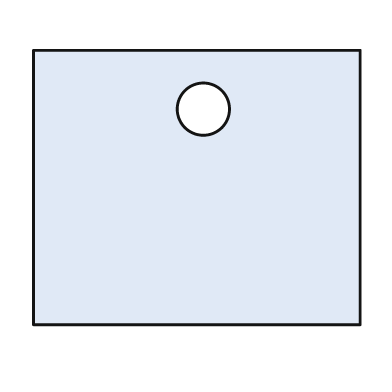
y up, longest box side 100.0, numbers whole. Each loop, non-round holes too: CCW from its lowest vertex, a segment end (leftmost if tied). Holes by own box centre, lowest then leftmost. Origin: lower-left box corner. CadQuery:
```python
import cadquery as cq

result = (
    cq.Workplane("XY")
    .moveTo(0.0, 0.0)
    .lineTo(100.0, 0.0)
    .lineTo(100.0, 84.0)
    .lineTo(0.0, 84.0)
    .close()
    .moveTo(52.0, 66.0)
    .circle(8.0)
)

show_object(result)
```